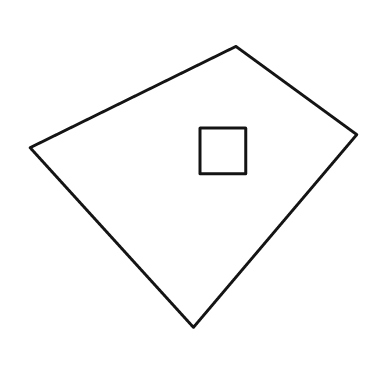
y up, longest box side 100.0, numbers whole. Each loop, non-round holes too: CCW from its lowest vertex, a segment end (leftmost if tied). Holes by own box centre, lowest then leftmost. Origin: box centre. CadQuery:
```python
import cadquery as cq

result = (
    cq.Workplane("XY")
    .moveTo(0.0, -43.0)
    .lineTo(50.0, 16.0)
    .lineTo(13.0, 43.0)
    .lineTo(-50.0, 12.0)
    .close()
    .moveTo(2.0, 4.0)
    .lineTo(16.0, 4.0)
    .lineTo(16.0, 18.0)
    .lineTo(2.0, 18.0)
    .close()
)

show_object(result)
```